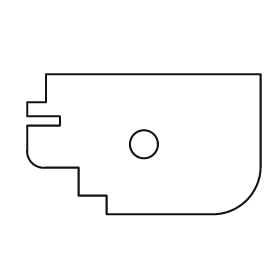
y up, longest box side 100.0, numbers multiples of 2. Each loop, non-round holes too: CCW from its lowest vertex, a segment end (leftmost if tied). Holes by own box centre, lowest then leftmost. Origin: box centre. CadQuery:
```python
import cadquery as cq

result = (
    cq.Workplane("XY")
    .moveTo(-16.0, -30.0)
    .lineTo(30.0, -30.0)
    .threePointArc((44.0, -24.0), (50.0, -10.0))
    .lineTo(50.0, 30.0)
    .lineTo(-42.0, 30.0)
    .lineTo(-42.0, 18.0)
    .lineTo(-50.0, 18.0)
    .lineTo(-50.0, 12.0)
    .lineTo(-36.0, 12.0)
    .lineTo(-36.0, 8.0)
    .lineTo(-50.0, 8.0)
    .lineTo(-50.0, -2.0)
    .threePointArc((-48.0, -8.0), (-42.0, -10.0))
    .lineTo(-28.0, -10.0)
    .lineTo(-28.0, -22.0)
    .lineTo(-16.0, -22.0)
    .close()
    .moveTo(0.0, 0.0)
    .circle(6.0)
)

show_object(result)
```